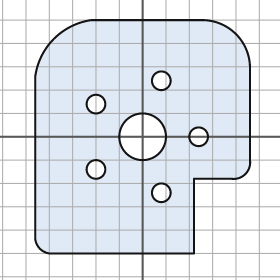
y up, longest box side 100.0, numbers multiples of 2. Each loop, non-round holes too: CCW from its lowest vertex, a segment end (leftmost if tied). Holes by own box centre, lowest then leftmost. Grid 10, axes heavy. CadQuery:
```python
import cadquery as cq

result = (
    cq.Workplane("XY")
    .moveTo(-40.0, -50.0)
    .lineTo(22.0, -50.0)
    .lineTo(22.0, -18.0)
    .lineTo(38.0, -18.0)
    .threePointArc((44.0, -16.0), (46.0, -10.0))
    .lineTo(46.0, 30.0)
    .threePointArc((40.0, 44.0), (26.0, 50.0))
    .lineTo(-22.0, 50.0)
    .threePointArc((-38.0, 42.0), (-46.0, 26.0))
    .lineTo(-46.0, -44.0)
    .threePointArc((-44.0, -48.0), (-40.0, -50.0))
    .close()
    .moveTo(8.0, -24.0)
    .circle(4.0)
    .moveTo(-20.0, -14.0)
    .circle(4.0)
    .moveTo(0.0, 0.0)
    .circle(10.0)
    .moveTo(24.0, 0.0)
    .circle(4.0)
    .moveTo(-20.0, 14.0)
    .circle(4.0)
    .moveTo(8.0, 24.0)
    .circle(4.0)
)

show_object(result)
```